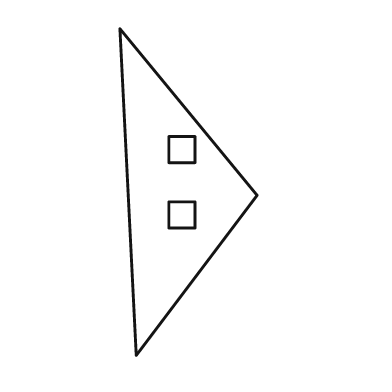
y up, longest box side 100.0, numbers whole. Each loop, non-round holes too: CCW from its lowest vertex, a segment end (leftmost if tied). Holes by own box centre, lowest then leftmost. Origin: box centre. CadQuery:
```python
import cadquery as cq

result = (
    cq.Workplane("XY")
    .moveTo(-16.0, -50.0)
    .lineTo(21.0, -1.0)
    .lineTo(-21.0, 50.0)
    .close()
    .moveTo(-6.0, -11.0)
    .lineTo(2.0, -11.0)
    .lineTo(2.0, -3.0)
    .lineTo(-6.0, -3.0)
    .close()
    .moveTo(-6.0, 9.0)
    .lineTo(2.0, 9.0)
    .lineTo(2.0, 17.0)
    .lineTo(-6.0, 17.0)
    .close()
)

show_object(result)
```